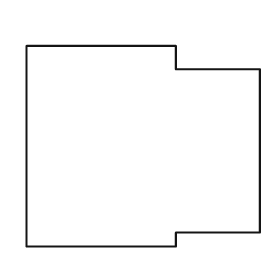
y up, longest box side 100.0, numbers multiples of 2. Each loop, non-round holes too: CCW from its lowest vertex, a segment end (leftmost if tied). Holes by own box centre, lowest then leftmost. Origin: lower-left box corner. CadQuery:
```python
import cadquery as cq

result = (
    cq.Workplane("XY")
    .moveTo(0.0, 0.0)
    .lineTo(64.0, 0.0)
    .lineTo(64.0, 6.0)
    .lineTo(100.0, 6.0)
    .lineTo(100.0, 76.0)
    .lineTo(64.0, 76.0)
    .lineTo(64.0, 86.0)
    .lineTo(0.0, 86.0)
    .close()
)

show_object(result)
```